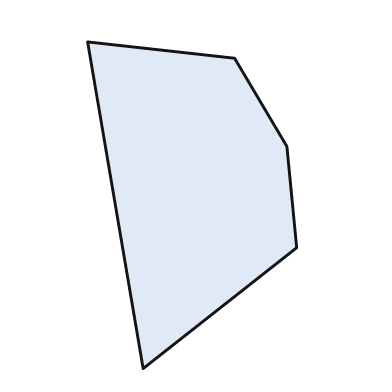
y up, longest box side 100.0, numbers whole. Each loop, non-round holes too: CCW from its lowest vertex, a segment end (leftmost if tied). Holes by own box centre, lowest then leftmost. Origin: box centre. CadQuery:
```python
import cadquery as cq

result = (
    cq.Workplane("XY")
    .moveTo(-15.0, -50.0)
    .lineTo(32.0, -13.0)
    .lineTo(29.0, 18.0)
    .lineTo(13.0, 45.0)
    .lineTo(-32.0, 50.0)
    .close()
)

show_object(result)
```